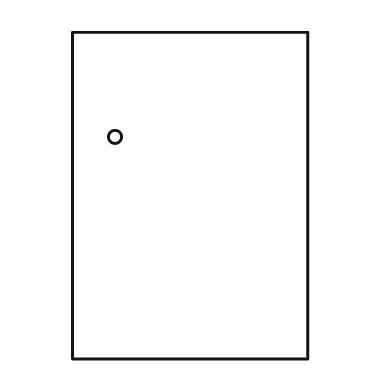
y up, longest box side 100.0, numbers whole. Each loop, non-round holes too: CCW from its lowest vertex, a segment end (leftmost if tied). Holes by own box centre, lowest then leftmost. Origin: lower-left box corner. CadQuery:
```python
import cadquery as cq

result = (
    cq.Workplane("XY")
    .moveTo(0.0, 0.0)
    .lineTo(72.0, 0.0)
    .lineTo(72.0, 100.0)
    .lineTo(0.0, 100.0)
    .close()
    .moveTo(13.0, 68.0)
    .circle(2.0)
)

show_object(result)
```